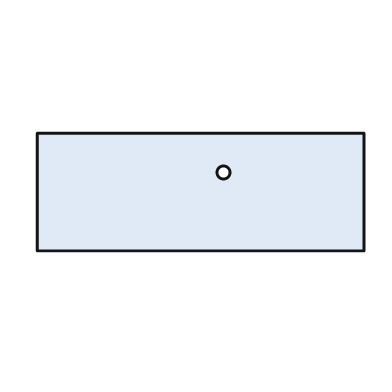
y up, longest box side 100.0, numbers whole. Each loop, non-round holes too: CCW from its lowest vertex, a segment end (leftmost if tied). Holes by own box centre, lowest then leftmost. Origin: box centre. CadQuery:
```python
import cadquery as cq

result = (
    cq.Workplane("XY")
    .moveTo(-50.0, -18.0)
    .lineTo(50.0, -18.0)
    .lineTo(50.0, 18.0)
    .lineTo(-50.0, 18.0)
    .close()
    .moveTo(7.0, 6.0)
    .circle(2.0)
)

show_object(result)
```